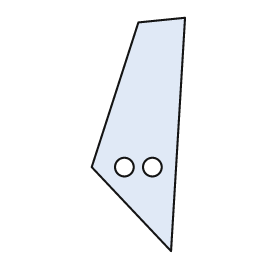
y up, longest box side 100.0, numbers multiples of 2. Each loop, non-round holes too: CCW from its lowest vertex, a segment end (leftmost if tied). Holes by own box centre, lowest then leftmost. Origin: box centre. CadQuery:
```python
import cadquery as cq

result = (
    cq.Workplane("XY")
    .moveTo(14.0, -50.0)
    .lineTo(20.0, 50.0)
    .lineTo(0.0, 48.0)
    .lineTo(-20.0, -14.0)
    .close()
    .moveTo(-6.0, -14.0)
    .circle(4.0)
    .moveTo(6.0, -14.0)
    .circle(4.0)
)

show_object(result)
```